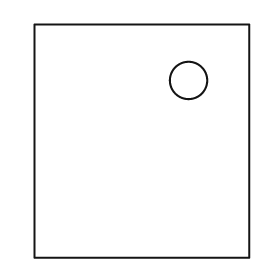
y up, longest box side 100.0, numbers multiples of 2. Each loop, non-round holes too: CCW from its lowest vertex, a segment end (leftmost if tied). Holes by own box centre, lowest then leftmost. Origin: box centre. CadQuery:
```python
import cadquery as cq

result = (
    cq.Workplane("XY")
    .moveTo(-46.0, -50.0)
    .lineTo(46.0, -50.0)
    .lineTo(46.0, 50.0)
    .lineTo(-46.0, 50.0)
    .close()
    .moveTo(20.0, 26.0)
    .circle(8.0)
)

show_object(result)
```